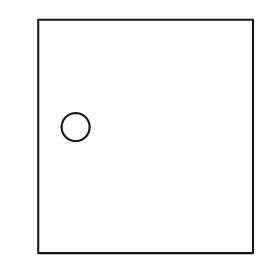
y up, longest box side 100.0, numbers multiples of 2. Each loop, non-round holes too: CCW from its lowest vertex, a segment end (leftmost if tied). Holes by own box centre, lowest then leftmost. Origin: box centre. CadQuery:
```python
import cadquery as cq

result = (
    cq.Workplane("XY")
    .moveTo(-46.0, -50.0)
    .lineTo(46.0, -50.0)
    .lineTo(46.0, 50.0)
    .lineTo(-46.0, 50.0)
    .close()
    .moveTo(-30.0, 4.0)
    .circle(6.0)
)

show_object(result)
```